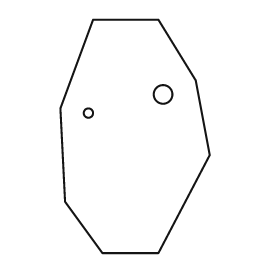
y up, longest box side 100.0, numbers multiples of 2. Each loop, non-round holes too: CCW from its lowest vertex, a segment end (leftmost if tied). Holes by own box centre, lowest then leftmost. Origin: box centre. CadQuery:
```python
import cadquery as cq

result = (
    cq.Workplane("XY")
    .moveTo(-14.0, -50.0)
    .lineTo(10.0, -50.0)
    .lineTo(32.0, -8.0)
    .lineTo(26.0, 24.0)
    .lineTo(10.0, 50.0)
    .lineTo(-18.0, 50.0)
    .lineTo(-32.0, 12.0)
    .lineTo(-30.0, -28.0)
    .close()
    .moveTo(-20.0, 10.0)
    .circle(2.0)
    .moveTo(12.0, 18.0)
    .circle(4.0)
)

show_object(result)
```